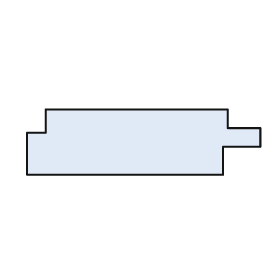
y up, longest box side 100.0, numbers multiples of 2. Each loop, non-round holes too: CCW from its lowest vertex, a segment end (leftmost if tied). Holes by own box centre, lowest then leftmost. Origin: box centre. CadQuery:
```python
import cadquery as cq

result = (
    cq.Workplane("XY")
    .moveTo(-50.0, -14.0)
    .lineTo(34.0, -14.0)
    .lineTo(34.0, -2.0)
    .lineTo(50.0, -2.0)
    .lineTo(50.0, 6.0)
    .lineTo(36.0, 6.0)
    .lineTo(36.0, 14.0)
    .lineTo(-42.0, 14.0)
    .lineTo(-42.0, 4.0)
    .lineTo(-50.0, 4.0)
    .close()
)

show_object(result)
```